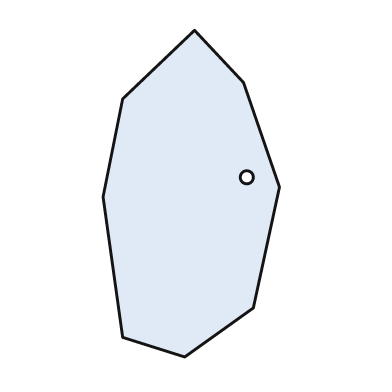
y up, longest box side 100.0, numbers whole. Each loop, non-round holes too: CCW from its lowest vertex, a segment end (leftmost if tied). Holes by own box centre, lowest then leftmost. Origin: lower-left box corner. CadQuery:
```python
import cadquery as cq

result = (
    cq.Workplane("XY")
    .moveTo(25.0, 0.0)
    .lineTo(46.0, 15.0)
    .lineTo(54.0, 52.0)
    .lineTo(43.0, 84.0)
    .lineTo(28.0, 100.0)
    .lineTo(6.0, 79.0)
    .lineTo(0.0, 49.0)
    .lineTo(6.0, 6.0)
    .close()
    .moveTo(44.0, 55.0)
    .circle(2.0)
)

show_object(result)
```